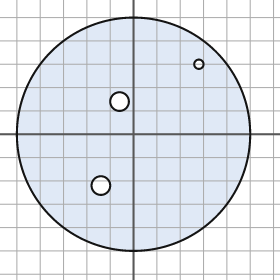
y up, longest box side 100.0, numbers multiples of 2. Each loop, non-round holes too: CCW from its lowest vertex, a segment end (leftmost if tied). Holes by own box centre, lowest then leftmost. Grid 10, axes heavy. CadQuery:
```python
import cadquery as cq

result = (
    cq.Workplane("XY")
    .moveTo(0.0, 0.0)
    .circle(50.0)
    .moveTo(-14.0, -22.0)
    .circle(4.0)
    .moveTo(-6.0, 14.0)
    .circle(4.0)
    .moveTo(28.0, 30.0)
    .circle(2.0)
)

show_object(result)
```